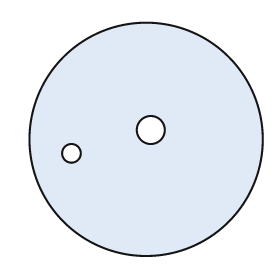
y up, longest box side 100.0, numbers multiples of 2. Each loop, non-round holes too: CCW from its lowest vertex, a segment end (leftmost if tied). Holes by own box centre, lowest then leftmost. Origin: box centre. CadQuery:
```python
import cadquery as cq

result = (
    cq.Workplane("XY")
    .moveTo(0.0, 0.0)
    .circle(50.0)
    .moveTo(-32.0, -6.0)
    .circle(4.0)
    .moveTo(2.0, 4.0)
    .circle(6.0)
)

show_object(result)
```